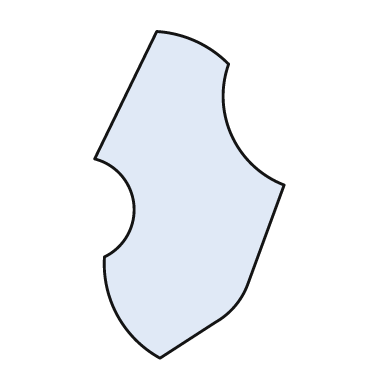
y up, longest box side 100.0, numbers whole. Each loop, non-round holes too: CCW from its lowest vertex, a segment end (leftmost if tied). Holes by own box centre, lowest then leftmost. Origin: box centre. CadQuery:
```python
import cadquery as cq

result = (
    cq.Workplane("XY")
    .moveTo(-9.0, -50.0)
    .lineTo(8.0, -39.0)
    .threePointArc((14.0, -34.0), (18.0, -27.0))
    .lineTo(29.0, 3.0)
    .threePointArc((13.0, 18.0), (12.0, 40.0))
    .threePointArc((2.0, 47.0), (-10.0, 50.0))
    .lineTo(-29.0, 11.0)
    .threePointArc((-17.0, -3.0), (-26.0, -19.0))
    .threePointArc((-22.0, -37.0), (-9.0, -50.0))
    .close()
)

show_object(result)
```